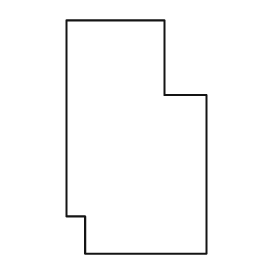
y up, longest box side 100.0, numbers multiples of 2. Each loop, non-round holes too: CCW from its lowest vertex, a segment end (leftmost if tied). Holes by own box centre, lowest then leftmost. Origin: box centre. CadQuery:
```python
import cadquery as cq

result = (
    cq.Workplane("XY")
    .moveTo(-22.0, -50.0)
    .lineTo(30.0, -50.0)
    .lineTo(30.0, 18.0)
    .lineTo(12.0, 18.0)
    .lineTo(12.0, 50.0)
    .lineTo(-30.0, 50.0)
    .lineTo(-30.0, -34.0)
    .lineTo(-22.0, -34.0)
    .close()
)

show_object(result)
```